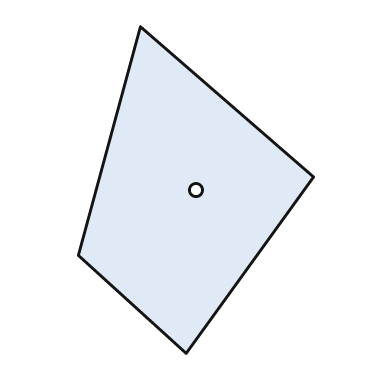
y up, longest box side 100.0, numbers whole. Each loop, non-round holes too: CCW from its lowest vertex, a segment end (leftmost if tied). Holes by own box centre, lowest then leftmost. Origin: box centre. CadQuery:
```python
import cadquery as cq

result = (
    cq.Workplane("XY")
    .moveTo(-3.0, -50.0)
    .lineTo(36.0, 4.0)
    .lineTo(-17.0, 50.0)
    .lineTo(-36.0, -20.0)
    .close()
    .moveTo(0.0, 0.0)
    .circle(2.0)
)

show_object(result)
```